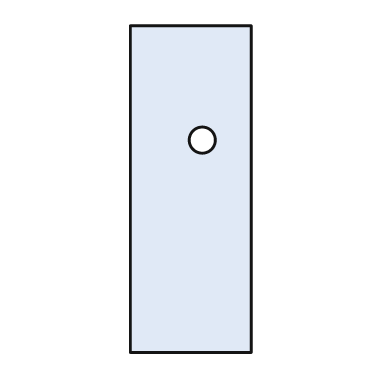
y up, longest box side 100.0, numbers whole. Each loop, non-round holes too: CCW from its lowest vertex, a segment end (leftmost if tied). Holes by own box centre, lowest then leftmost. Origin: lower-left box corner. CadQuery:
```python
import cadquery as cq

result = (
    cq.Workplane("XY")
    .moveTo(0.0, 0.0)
    .lineTo(37.0, 0.0)
    .lineTo(37.0, 100.0)
    .lineTo(0.0, 100.0)
    .close()
    .moveTo(22.0, 65.0)
    .circle(4.0)
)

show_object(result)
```